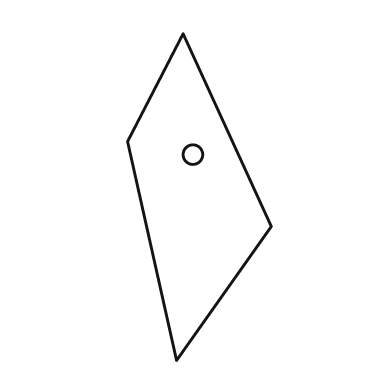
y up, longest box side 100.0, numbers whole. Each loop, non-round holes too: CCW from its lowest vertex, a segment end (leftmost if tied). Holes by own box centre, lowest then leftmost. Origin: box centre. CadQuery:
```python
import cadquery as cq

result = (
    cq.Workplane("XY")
    .moveTo(-7.0, -50.0)
    .lineTo(22.0, -9.0)
    .lineTo(-5.0, 50.0)
    .lineTo(-22.0, 17.0)
    .close()
    .moveTo(-2.0, 13.0)
    .circle(3.0)
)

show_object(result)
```